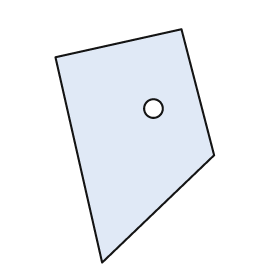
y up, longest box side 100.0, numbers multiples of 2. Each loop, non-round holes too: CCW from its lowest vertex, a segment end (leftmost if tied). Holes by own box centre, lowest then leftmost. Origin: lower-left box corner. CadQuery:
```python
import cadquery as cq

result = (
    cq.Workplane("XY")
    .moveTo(20.0, 0.0)
    .lineTo(68.0, 46.0)
    .lineTo(54.0, 100.0)
    .lineTo(0.0, 88.0)
    .close()
    .moveTo(42.0, 66.0)
    .circle(4.0)
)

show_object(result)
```